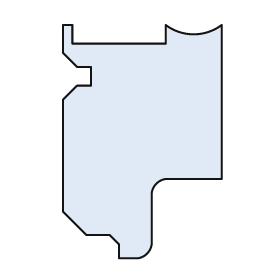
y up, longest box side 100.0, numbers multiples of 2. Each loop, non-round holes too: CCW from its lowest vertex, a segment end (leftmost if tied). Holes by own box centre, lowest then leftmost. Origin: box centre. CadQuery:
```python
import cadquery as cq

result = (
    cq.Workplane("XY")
    .moveTo(-10.0, -50.0)
    .lineTo(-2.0, -50.0)
    .threePointArc((2.0, -48.0), (4.0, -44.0))
    .lineTo(4.0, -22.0)
    .threePointArc((6.0, -18.0), (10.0, -16.0))
    .lineTo(34.0, -16.0)
    .lineTo(34.0, 50.0)
    .threePointArc((22.0, 46.0), (10.0, 50.0))
    .lineTo(10.0, 42.0)
    .lineTo(-30.0, 42.0)
    .lineTo(-30.0, 50.0)
    .lineTo(-34.0, 50.0)
    .lineTo(-34.0, 38.0)
    .lineTo(-28.0, 32.0)
    .lineTo(-22.0, 32.0)
    .lineTo(-22.0, 24.0)
    .lineTo(-28.0, 24.0)
    .lineTo(-34.0, 18.0)
    .lineTo(-34.0, -30.0)
    .lineTo(-24.0, -40.0)
    .lineTo(-14.0, -40.0)
    .lineTo(-10.0, -44.0)
    .close()
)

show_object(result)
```